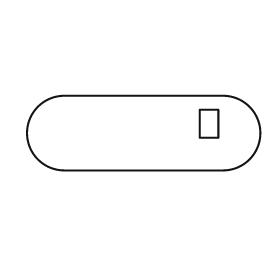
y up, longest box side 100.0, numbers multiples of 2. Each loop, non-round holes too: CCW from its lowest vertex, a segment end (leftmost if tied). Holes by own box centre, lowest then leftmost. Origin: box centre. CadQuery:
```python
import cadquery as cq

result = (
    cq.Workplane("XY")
    .moveTo(-34.0, -16.0)
    .lineTo(34.0, -16.0)
    .threePointArc((50.0, 0.0), (34.0, 16.0))
    .lineTo(-34.0, 16.0)
    .threePointArc((-50.0, 0.0), (-34.0, -16.0))
    .close()
    .moveTo(24.0, -2.0)
    .lineTo(32.0, -2.0)
    .lineTo(32.0, 10.0)
    .lineTo(24.0, 10.0)
    .close()
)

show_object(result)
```